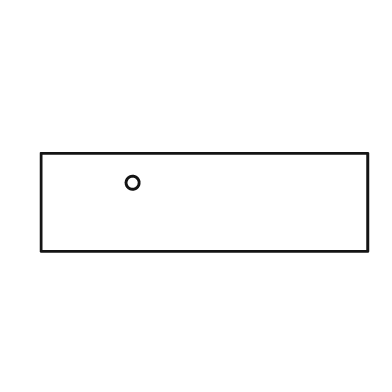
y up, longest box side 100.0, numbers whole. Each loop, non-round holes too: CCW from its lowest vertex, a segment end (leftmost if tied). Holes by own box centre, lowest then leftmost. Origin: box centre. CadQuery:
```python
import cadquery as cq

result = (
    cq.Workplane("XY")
    .moveTo(-50.0, -15.0)
    .lineTo(50.0, -15.0)
    .lineTo(50.0, 15.0)
    .lineTo(-50.0, 15.0)
    .close()
    .moveTo(-22.0, 6.0)
    .circle(2.0)
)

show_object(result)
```